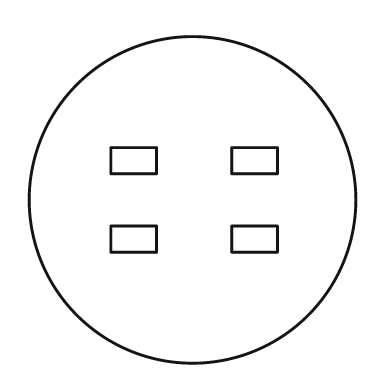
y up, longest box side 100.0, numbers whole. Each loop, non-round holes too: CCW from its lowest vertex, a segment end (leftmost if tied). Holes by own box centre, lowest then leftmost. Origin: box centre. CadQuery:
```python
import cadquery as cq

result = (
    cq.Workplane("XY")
    .moveTo(0.0, 0.0)
    .circle(50.0)
    .moveTo(-25.0, -16.0)
    .lineTo(-11.0, -16.0)
    .lineTo(-11.0, -8.0)
    .lineTo(-25.0, -8.0)
    .close()
    .moveTo(12.0, -16.0)
    .lineTo(26.0, -16.0)
    .lineTo(26.0, -8.0)
    .lineTo(12.0, -8.0)
    .close()
    .moveTo(-25.0, 8.0)
    .lineTo(-11.0, 8.0)
    .lineTo(-11.0, 16.0)
    .lineTo(-25.0, 16.0)
    .close()
    .moveTo(12.0, 8.0)
    .lineTo(26.0, 8.0)
    .lineTo(26.0, 16.0)
    .lineTo(12.0, 16.0)
    .close()
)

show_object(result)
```